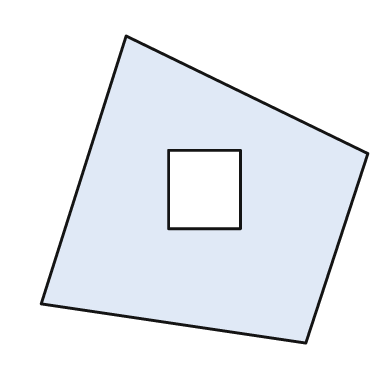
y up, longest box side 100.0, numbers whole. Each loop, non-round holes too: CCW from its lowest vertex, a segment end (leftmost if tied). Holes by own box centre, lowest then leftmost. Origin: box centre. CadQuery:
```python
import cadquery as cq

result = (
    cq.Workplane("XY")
    .moveTo(31.0, -47.0)
    .lineTo(50.0, 11.0)
    .lineTo(-24.0, 47.0)
    .lineTo(-50.0, -35.0)
    .close()
    .moveTo(-11.0, -12.0)
    .lineTo(11.0, -12.0)
    .lineTo(11.0, 12.0)
    .lineTo(-11.0, 12.0)
    .close()
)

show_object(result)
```